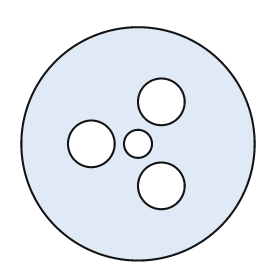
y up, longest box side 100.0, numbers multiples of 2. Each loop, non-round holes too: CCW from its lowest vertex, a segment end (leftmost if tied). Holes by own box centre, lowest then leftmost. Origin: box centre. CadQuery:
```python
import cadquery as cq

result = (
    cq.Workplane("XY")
    .moveTo(0.0, 0.0)
    .circle(50.0)
    .moveTo(10.0, -18.0)
    .circle(10.0)
    .moveTo(-20.0, 0.0)
    .circle(10.0)
    .moveTo(0.0, 0.0)
    .circle(6.0)
    .moveTo(10.0, 18.0)
    .circle(10.0)
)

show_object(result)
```